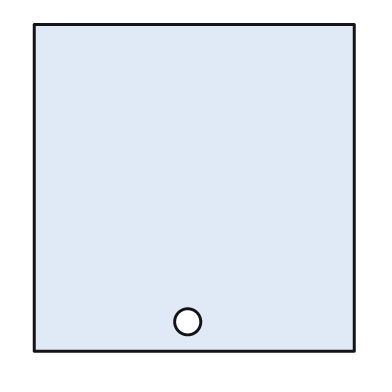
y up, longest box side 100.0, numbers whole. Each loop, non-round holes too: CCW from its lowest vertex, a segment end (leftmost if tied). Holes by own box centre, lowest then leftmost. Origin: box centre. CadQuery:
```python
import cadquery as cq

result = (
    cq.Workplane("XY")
    .moveTo(-49.0, -50.0)
    .lineTo(49.0, -50.0)
    .lineTo(49.0, 50.0)
    .lineTo(-49.0, 50.0)
    .close()
    .moveTo(-2.0, -41.0)
    .circle(4.0)
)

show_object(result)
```